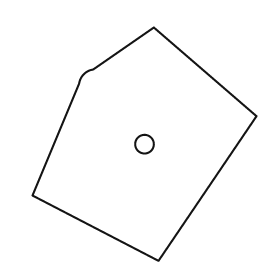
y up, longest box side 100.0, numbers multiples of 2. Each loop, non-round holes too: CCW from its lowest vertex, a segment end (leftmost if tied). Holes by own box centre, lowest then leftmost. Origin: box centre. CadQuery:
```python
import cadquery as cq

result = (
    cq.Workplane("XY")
    .moveTo(6.0, -50.0)
    .lineTo(48.0, 12.0)
    .lineTo(4.0, 50.0)
    .lineTo(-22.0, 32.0)
    .threePointArc((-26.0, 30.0), (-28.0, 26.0))
    .lineTo(-48.0, -22.0)
    .close()
    .moveTo(0.0, 0.0)
    .circle(4.0)
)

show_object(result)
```